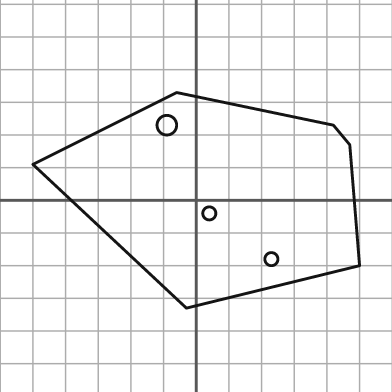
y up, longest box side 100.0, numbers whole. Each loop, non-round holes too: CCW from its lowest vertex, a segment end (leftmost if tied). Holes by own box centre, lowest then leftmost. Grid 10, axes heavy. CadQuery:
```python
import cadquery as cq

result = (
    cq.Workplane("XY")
    .moveTo(-3.0, -33.0)
    .lineTo(50.0, -20.0)
    .lineTo(47.0, 17.0)
    .lineTo(42.0, 23.0)
    .lineTo(-6.0, 33.0)
    .lineTo(-50.0, 11.0)
    .close()
    .moveTo(23.0, -18.0)
    .circle(2.0)
    .moveTo(4.0, -4.0)
    .circle(2.0)
    .moveTo(-9.0, 23.0)
    .circle(3.0)
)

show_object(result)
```